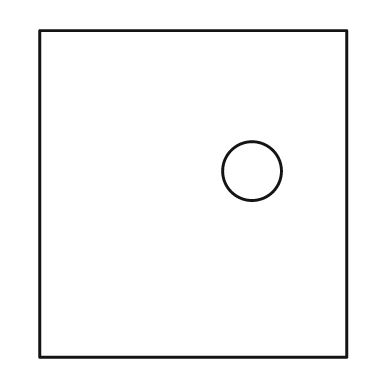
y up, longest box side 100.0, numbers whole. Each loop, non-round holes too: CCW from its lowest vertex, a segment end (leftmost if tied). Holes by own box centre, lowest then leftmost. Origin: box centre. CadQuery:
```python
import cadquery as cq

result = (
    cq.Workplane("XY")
    .moveTo(-47.0, -50.0)
    .lineTo(47.0, -50.0)
    .lineTo(47.0, 50.0)
    .lineTo(-47.0, 50.0)
    .close()
    .moveTo(18.0, 7.0)
    .circle(9.0)
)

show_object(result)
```